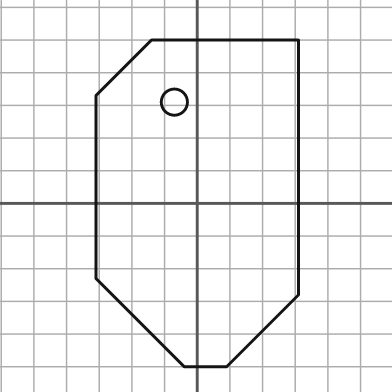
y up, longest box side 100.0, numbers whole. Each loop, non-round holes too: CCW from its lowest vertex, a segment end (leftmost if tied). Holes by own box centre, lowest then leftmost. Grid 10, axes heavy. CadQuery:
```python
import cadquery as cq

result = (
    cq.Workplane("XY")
    .moveTo(-4.0, -50.0)
    .lineTo(9.0, -50.0)
    .lineTo(31.0, -28.0)
    .lineTo(31.0, 50.0)
    .lineTo(-14.0, 50.0)
    .lineTo(-31.0, 33.0)
    .lineTo(-31.0, -23.0)
    .close()
    .moveTo(-7.0, 31.0)
    .circle(4.0)
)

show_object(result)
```